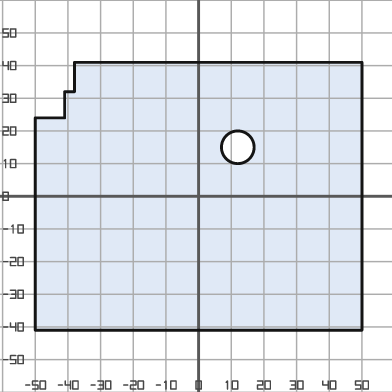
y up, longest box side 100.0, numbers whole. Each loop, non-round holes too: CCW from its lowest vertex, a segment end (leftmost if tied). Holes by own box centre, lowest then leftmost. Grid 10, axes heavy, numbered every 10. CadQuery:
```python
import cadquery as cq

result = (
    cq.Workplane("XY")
    .moveTo(-50.0, -41.0)
    .lineTo(50.0, -41.0)
    .lineTo(50.0, 41.0)
    .lineTo(-38.0, 41.0)
    .lineTo(-38.0, 32.0)
    .lineTo(-41.0, 32.0)
    .lineTo(-41.0, 24.0)
    .lineTo(-50.0, 24.0)
    .close()
    .moveTo(12.0, 15.0)
    .circle(5.0)
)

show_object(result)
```